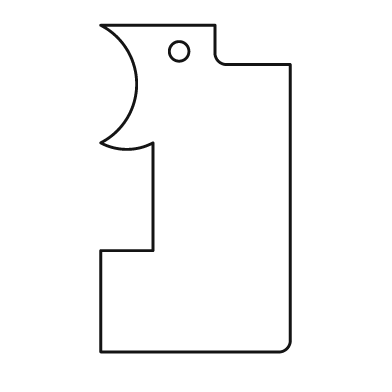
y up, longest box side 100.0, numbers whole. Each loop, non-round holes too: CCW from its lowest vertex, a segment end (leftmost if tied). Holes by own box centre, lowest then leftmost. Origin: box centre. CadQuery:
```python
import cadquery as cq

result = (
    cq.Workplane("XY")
    .moveTo(-29.0, -50.0)
    .lineTo(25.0, -50.0)
    .threePointArc((28.0, -49.0), (29.0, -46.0))
    .lineTo(29.0, 38.0)
    .lineTo(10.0, 38.0)
    .threePointArc((7.0, 39.0), (6.0, 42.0))
    .lineTo(6.0, 50.0)
    .lineTo(-29.0, 50.0)
    .threePointArc((-18.0, 32.0), (-29.0, 14.0))
    .threePointArc((-21.0, 12.0), (-13.0, 14.0))
    .lineTo(-13.0, -19.0)
    .lineTo(-29.0, -19.0)
    .close()
    .moveTo(-5.0, 42.0)
    .circle(3.0)
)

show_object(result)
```